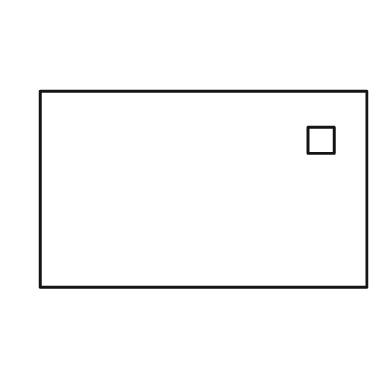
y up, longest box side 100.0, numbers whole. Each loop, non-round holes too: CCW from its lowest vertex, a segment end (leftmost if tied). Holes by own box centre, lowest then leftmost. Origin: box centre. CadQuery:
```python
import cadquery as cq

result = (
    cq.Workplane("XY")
    .moveTo(-50.0, -30.0)
    .lineTo(50.0, -30.0)
    .lineTo(50.0, 30.0)
    .lineTo(-50.0, 30.0)
    .close()
    .moveTo(32.0, 11.0)
    .lineTo(40.0, 11.0)
    .lineTo(40.0, 19.0)
    .lineTo(32.0, 19.0)
    .close()
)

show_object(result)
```